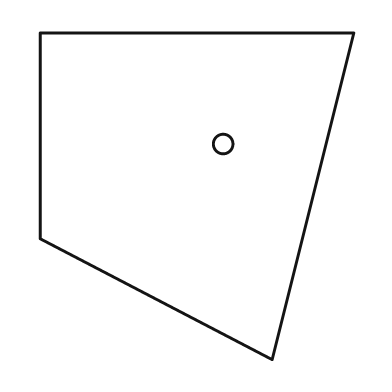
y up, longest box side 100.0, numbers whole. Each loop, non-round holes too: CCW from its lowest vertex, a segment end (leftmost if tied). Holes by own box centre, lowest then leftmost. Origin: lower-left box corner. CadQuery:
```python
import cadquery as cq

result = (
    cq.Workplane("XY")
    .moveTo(71.0, 0.0)
    .lineTo(96.0, 100.0)
    .lineTo(0.0, 100.0)
    .lineTo(0.0, 37.0)
    .close()
    .moveTo(56.0, 66.0)
    .circle(3.0)
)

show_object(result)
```